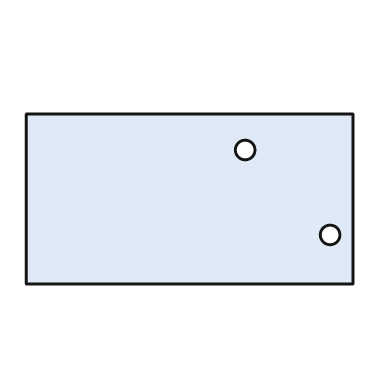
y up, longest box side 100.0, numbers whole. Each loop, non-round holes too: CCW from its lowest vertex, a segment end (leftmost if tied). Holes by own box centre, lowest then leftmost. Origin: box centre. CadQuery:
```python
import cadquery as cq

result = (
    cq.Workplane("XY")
    .moveTo(-50.0, -26.0)
    .lineTo(50.0, -26.0)
    .lineTo(50.0, 26.0)
    .lineTo(-50.0, 26.0)
    .close()
    .moveTo(43.0, -11.0)
    .circle(3.0)
    .moveTo(17.0, 15.0)
    .circle(3.0)
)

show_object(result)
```